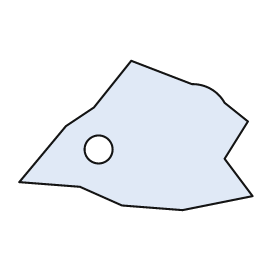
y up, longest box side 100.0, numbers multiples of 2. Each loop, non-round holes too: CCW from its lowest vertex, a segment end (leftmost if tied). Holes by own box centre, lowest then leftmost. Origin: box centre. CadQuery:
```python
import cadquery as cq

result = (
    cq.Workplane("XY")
    .moveTo(20.0, -32.0)
    .lineTo(50.0, -26.0)
    .lineTo(38.0, -10.0)
    .lineTo(48.0, 6.0)
    .lineTo(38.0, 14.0)
    .threePointArc((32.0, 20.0), (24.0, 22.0))
    .lineTo(-2.0, 32.0)
    .lineTo(-18.0, 12.0)
    .lineTo(-30.0, 4.0)
    .lineTo(-50.0, -20.0)
    .lineTo(-24.0, -22.0)
    .lineTo(-6.0, -30.0)
    .close()
    .moveTo(-16.0, -6.0)
    .circle(6.0)
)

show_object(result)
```